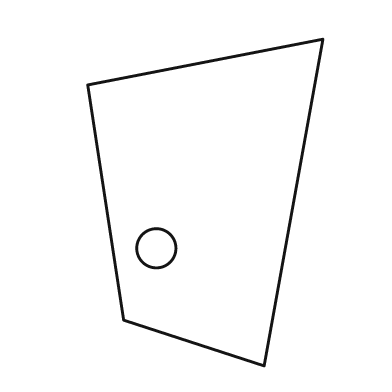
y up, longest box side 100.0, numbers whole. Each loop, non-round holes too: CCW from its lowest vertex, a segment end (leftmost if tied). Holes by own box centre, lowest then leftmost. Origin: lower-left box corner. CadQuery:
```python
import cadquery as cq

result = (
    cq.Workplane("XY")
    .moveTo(54.0, 0.0)
    .lineTo(72.0, 100.0)
    .lineTo(0.0, 86.0)
    .lineTo(11.0, 14.0)
    .close()
    .moveTo(21.0, 36.0)
    .circle(6.0)
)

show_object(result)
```